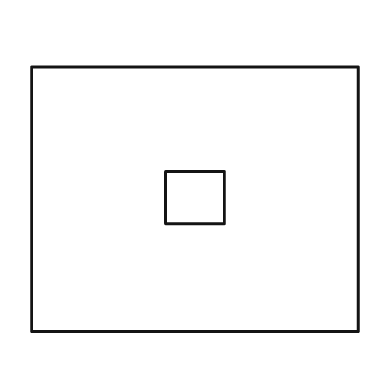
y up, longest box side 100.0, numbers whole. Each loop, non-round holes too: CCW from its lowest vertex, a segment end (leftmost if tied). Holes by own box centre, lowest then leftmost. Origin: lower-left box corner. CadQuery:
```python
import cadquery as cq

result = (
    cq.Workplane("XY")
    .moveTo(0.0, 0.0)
    .lineTo(100.0, 0.0)
    .lineTo(100.0, 81.0)
    .lineTo(0.0, 81.0)
    .close()
    .moveTo(41.0, 33.0)
    .lineTo(59.0, 33.0)
    .lineTo(59.0, 49.0)
    .lineTo(41.0, 49.0)
    .close()
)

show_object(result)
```